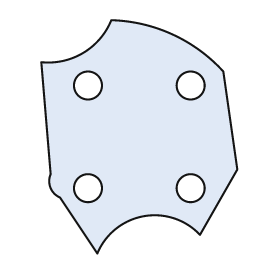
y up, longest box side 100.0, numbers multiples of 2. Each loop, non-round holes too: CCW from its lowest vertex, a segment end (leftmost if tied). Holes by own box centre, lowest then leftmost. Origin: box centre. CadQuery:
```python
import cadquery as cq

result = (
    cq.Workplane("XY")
    .moveTo(-18.0, -50.0)
    .threePointArc((2.0, -34.0), (26.0, -42.0))
    .lineTo(42.0, -14.0)
    .lineTo(36.0, 28.0)
    .threePointArc((14.0, 44.0), (-12.0, 50.0))
    .threePointArc((-24.0, 36.0), (-42.0, 32.0))
    .lineTo(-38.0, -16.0)
    .threePointArc((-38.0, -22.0), (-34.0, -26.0))
    .close()
    .moveTo(-22.0, -22.0)
    .circle(6.0)
    .moveTo(22.0, -22.0)
    .circle(6.0)
    .moveTo(-22.0, 22.0)
    .circle(6.0)
    .moveTo(22.0, 22.0)
    .circle(6.0)
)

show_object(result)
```